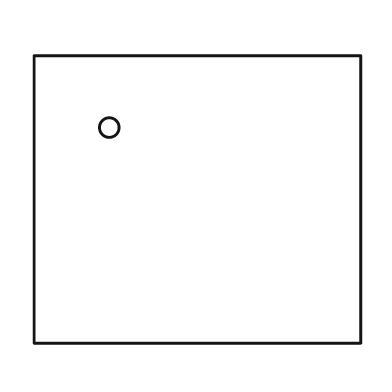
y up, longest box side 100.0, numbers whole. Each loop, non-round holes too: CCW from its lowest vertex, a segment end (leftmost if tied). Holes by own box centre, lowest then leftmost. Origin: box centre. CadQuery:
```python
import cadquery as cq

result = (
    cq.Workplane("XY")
    .moveTo(-50.0, -44.0)
    .lineTo(50.0, -44.0)
    .lineTo(50.0, 44.0)
    .lineTo(-50.0, 44.0)
    .close()
    .moveTo(-27.0, 22.0)
    .circle(3.0)
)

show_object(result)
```